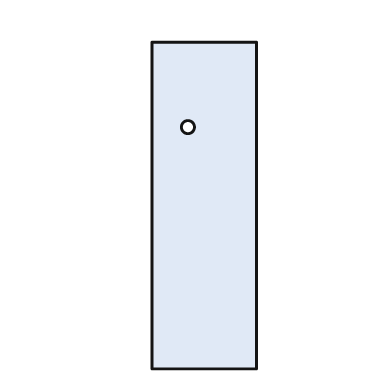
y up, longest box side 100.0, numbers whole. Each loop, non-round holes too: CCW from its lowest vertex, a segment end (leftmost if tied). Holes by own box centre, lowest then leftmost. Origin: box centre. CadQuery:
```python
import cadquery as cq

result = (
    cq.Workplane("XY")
    .moveTo(-16.0, -50.0)
    .lineTo(16.0, -50.0)
    .lineTo(16.0, 50.0)
    .lineTo(-16.0, 50.0)
    .close()
    .moveTo(-5.0, 24.0)
    .circle(2.0)
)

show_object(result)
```